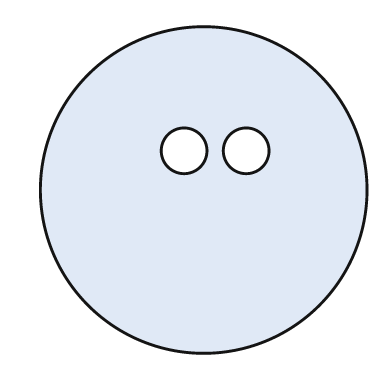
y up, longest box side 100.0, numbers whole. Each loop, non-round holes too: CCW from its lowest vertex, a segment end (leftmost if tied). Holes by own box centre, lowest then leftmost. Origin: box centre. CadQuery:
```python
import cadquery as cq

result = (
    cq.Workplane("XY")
    .moveTo(0.0, 0.0)
    .circle(50.0)
    .moveTo(-6.0, 12.0)
    .circle(7.0)
    .moveTo(13.0, 12.0)
    .circle(7.0)
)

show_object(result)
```